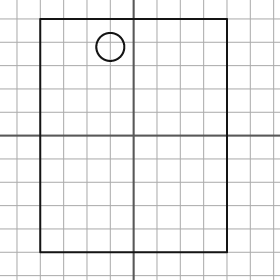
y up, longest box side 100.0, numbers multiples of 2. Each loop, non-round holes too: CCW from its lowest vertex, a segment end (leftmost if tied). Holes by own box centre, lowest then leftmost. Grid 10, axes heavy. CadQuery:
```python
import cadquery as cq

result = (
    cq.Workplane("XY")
    .moveTo(-40.0, -50.0)
    .lineTo(40.0, -50.0)
    .lineTo(40.0, 50.0)
    .lineTo(-40.0, 50.0)
    .close()
    .moveTo(-10.0, 38.0)
    .circle(6.0)
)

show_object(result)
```